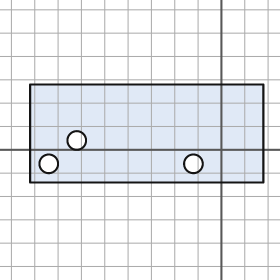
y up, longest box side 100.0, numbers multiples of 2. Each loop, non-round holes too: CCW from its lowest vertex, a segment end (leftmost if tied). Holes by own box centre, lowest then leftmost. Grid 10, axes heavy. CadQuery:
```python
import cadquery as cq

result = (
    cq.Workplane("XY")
    .moveTo(-82.0, -14.0)
    .lineTo(18.0, -14.0)
    .lineTo(18.0, 28.0)
    .lineTo(-82.0, 28.0)
    .close()
    .moveTo(-74.0, -6.0)
    .circle(4.0)
    .moveTo(-12.0, -6.0)
    .circle(4.0)
    .moveTo(-62.0, 4.0)
    .circle(4.0)
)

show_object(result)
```